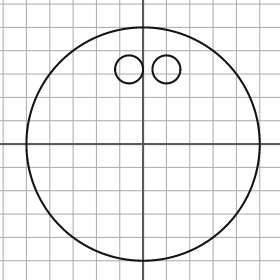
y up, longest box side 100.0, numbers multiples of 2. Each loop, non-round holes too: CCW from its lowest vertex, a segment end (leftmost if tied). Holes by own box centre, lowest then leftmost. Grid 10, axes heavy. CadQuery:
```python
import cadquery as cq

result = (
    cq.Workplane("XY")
    .moveTo(0.0, 0.0)
    .circle(50.0)
    .moveTo(-6.0, 32.0)
    .circle(6.0)
    .moveTo(10.0, 32.0)
    .circle(6.0)
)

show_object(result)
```